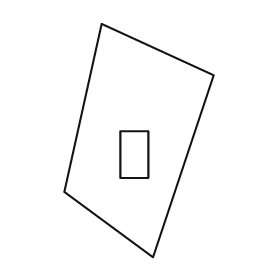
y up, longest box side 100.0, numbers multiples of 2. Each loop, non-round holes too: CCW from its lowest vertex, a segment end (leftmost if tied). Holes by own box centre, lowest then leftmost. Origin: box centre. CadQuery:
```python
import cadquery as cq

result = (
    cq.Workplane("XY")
    .moveTo(6.0, -50.0)
    .lineTo(32.0, 28.0)
    .lineTo(-16.0, 50.0)
    .lineTo(-32.0, -22.0)
    .close()
    .moveTo(-8.0, -16.0)
    .lineTo(4.0, -16.0)
    .lineTo(4.0, 4.0)
    .lineTo(-8.0, 4.0)
    .close()
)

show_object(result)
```